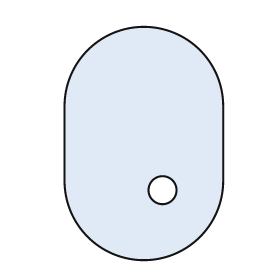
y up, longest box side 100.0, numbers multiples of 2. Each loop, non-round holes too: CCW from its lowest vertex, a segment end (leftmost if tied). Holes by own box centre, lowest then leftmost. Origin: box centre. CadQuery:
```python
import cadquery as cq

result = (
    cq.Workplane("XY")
    .moveTo(-34.0, -16.0)
    .threePointArc((0.0, -50.0), (34.0, -16.0))
    .lineTo(34.0, 16.0)
    .threePointArc((0.0, 50.0), (-34.0, 16.0))
    .close()
    .moveTo(8.0, -20.0)
    .circle(6.0)
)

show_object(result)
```